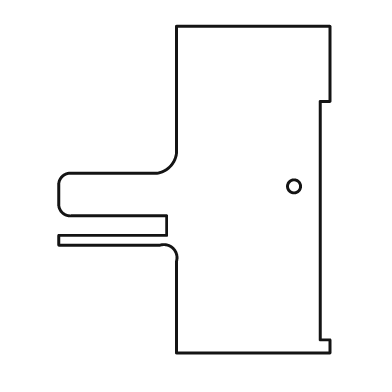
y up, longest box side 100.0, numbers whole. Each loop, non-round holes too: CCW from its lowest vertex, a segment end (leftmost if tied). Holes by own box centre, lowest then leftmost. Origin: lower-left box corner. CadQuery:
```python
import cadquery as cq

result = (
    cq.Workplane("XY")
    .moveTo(36.0, 0.0)
    .lineTo(83.0, 0.0)
    .lineTo(83.0, 4.0)
    .lineTo(80.0, 4.0)
    .lineTo(80.0, 77.0)
    .lineTo(83.0, 77.0)
    .lineTo(83.0, 100.0)
    .lineTo(36.0, 100.0)
    .lineTo(36.0, 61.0)
    .threePointArc((34.0, 57.0), (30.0, 55.0))
    .lineTo(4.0, 55.0)
    .threePointArc((1.0, 54.0), (0.0, 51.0))
    .lineTo(0.0, 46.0)
    .threePointArc((1.0, 43.0), (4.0, 42.0))
    .lineTo(33.0, 42.0)
    .lineTo(33.0, 36.0)
    .lineTo(0.0, 36.0)
    .lineTo(0.0, 33.0)
    .lineTo(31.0, 33.0)
    .threePointArc((35.0, 32.0), (36.0, 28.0))
    .close()
    .moveTo(72.0, 51.0)
    .circle(2.0)
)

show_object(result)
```